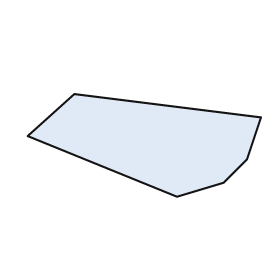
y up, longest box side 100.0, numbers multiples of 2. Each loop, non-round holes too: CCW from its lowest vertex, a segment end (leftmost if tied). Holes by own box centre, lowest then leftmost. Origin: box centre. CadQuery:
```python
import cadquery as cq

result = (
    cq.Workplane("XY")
    .moveTo(14.0, -22.0)
    .lineTo(34.0, -16.0)
    .lineTo(44.0, -6.0)
    .lineTo(50.0, 12.0)
    .lineTo(-30.0, 22.0)
    .lineTo(-50.0, 4.0)
    .close()
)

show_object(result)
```